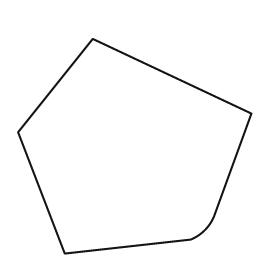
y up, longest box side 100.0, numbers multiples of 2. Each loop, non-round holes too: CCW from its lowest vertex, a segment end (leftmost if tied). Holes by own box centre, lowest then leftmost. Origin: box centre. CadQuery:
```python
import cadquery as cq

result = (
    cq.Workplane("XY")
    .moveTo(-30.0, -46.0)
    .lineTo(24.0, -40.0)
    .threePointArc((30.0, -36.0), (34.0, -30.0))
    .lineTo(50.0, 14.0)
    .lineTo(-18.0, 46.0)
    .lineTo(-50.0, 6.0)
    .close()
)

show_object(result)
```